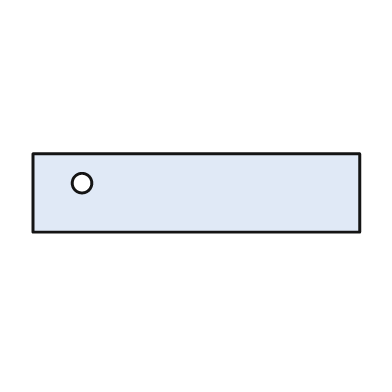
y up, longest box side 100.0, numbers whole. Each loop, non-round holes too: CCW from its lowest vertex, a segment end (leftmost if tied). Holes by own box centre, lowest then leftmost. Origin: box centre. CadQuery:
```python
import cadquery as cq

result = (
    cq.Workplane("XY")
    .moveTo(-50.0, -12.0)
    .lineTo(50.0, -12.0)
    .lineTo(50.0, 12.0)
    .lineTo(-50.0, 12.0)
    .close()
    .moveTo(-35.0, 3.0)
    .circle(3.0)
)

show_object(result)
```